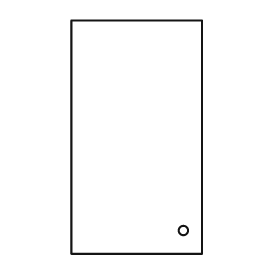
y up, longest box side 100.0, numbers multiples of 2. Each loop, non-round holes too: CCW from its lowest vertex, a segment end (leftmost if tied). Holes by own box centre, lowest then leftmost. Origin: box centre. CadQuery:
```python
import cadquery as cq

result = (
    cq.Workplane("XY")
    .moveTo(-28.0, -50.0)
    .lineTo(28.0, -50.0)
    .lineTo(28.0, 50.0)
    .lineTo(-28.0, 50.0)
    .close()
    .moveTo(20.0, -40.0)
    .circle(2.0)
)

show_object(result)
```